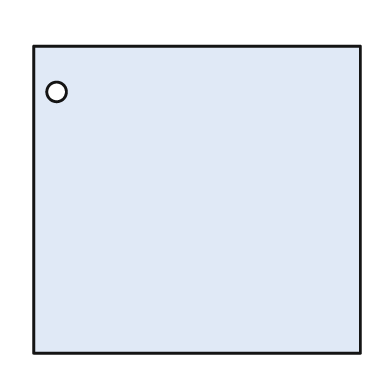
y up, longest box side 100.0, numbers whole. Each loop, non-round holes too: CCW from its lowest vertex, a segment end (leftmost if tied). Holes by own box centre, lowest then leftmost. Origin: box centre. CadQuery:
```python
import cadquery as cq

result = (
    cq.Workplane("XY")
    .moveTo(-50.0, -47.0)
    .lineTo(50.0, -47.0)
    .lineTo(50.0, 47.0)
    .lineTo(-50.0, 47.0)
    .close()
    .moveTo(-43.0, 33.0)
    .circle(3.0)
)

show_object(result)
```